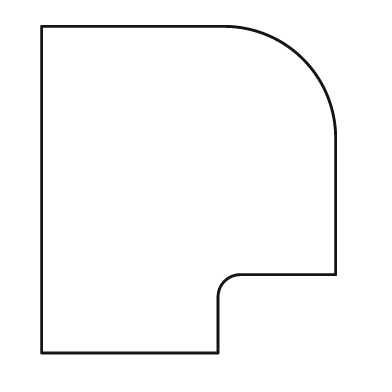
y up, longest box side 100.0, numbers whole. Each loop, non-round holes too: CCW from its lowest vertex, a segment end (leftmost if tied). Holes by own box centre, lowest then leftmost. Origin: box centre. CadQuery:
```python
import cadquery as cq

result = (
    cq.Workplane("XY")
    .moveTo(-45.0, -50.0)
    .lineTo(9.0, -50.0)
    .lineTo(9.0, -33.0)
    .threePointArc((11.0, -28.0), (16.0, -26.0))
    .lineTo(45.0, -26.0)
    .lineTo(45.0, 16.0)
    .threePointArc((35.0, 40.0), (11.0, 50.0))
    .lineTo(-45.0, 50.0)
    .close()
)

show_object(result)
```